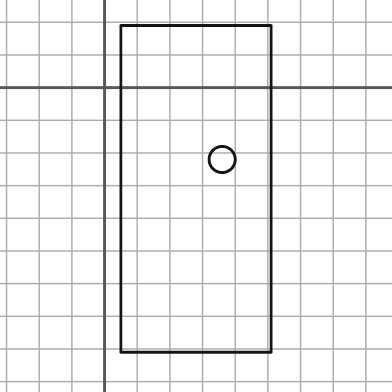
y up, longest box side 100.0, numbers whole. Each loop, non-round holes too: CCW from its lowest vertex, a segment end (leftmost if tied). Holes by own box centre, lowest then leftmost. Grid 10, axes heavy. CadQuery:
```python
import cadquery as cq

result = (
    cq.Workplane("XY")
    .moveTo(5.0, -81.0)
    .lineTo(51.0, -81.0)
    .lineTo(51.0, 19.0)
    .lineTo(5.0, 19.0)
    .close()
    .moveTo(36.0, -22.0)
    .circle(4.0)
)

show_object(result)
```